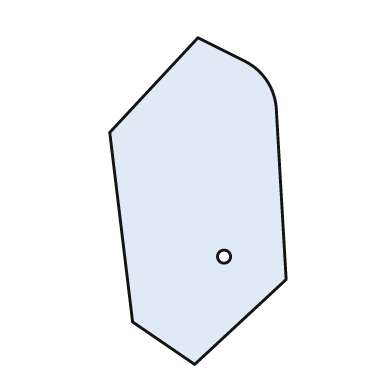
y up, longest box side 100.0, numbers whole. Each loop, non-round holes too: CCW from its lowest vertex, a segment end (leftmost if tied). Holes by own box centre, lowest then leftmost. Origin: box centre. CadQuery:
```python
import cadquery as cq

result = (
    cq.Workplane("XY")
    .moveTo(-1.0, -50.0)
    .lineTo(27.0, -24.0)
    .lineTo(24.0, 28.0)
    .threePointArc((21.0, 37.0), (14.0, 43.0))
    .lineTo(0.0, 50.0)
    .lineTo(-27.0, 21.0)
    .lineTo(-20.0, -37.0)
    .close()
    .moveTo(8.0, -17.0)
    .circle(2.0)
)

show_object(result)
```